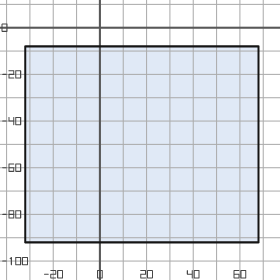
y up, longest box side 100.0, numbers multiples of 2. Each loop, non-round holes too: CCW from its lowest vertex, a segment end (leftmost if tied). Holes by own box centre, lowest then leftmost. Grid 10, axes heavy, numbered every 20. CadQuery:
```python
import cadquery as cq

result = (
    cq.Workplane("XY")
    .moveTo(-32.0, -92.0)
    .lineTo(68.0, -92.0)
    .lineTo(68.0, -8.0)
    .lineTo(-32.0, -8.0)
    .close()
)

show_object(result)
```